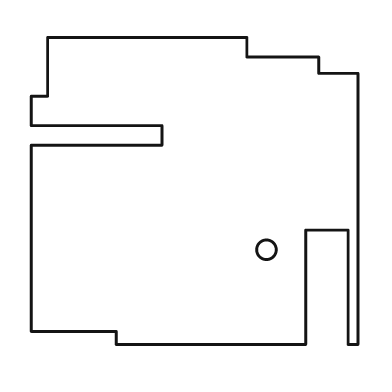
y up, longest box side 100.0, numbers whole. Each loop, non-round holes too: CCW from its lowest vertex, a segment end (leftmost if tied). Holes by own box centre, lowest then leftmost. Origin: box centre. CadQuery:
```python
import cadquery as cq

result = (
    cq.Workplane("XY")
    .moveTo(-24.0, -47.0)
    .lineTo(34.0, -47.0)
    .lineTo(34.0, -12.0)
    .lineTo(47.0, -12.0)
    .lineTo(47.0, -47.0)
    .lineTo(50.0, -47.0)
    .lineTo(50.0, 36.0)
    .lineTo(38.0, 36.0)
    .lineTo(38.0, 41.0)
    .lineTo(16.0, 41.0)
    .lineTo(16.0, 47.0)
    .lineTo(-45.0, 47.0)
    .lineTo(-45.0, 29.0)
    .lineTo(-50.0, 29.0)
    .lineTo(-50.0, 20.0)
    .lineTo(-10.0, 20.0)
    .lineTo(-10.0, 14.0)
    .lineTo(-50.0, 14.0)
    .lineTo(-50.0, -43.0)
    .lineTo(-24.0, -43.0)
    .close()
    .moveTo(22.0, -18.0)
    .circle(3.0)
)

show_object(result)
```